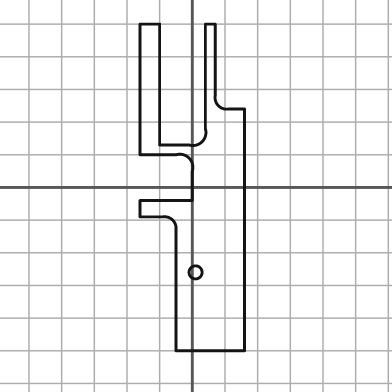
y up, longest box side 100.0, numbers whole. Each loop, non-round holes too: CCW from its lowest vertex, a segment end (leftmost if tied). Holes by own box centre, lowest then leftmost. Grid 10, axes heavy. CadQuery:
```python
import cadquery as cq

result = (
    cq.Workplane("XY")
    .moveTo(-5.0, -50.0)
    .lineTo(16.0, -50.0)
    .lineTo(16.0, 24.0)
    .lineTo(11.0, 24.0)
    .threePointArc((8.0, 25.0), (7.0, 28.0))
    .lineTo(7.0, 50.0)
    .lineTo(4.0, 50.0)
    .lineTo(4.0, 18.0)
    .threePointArc((3.0, 14.0), (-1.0, 13.0))
    .lineTo(-10.0, 13.0)
    .lineTo(-10.0, 50.0)
    .lineTo(-16.0, 50.0)
    .lineTo(-16.0, 10.0)
    .lineTo(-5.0, 10.0)
    .threePointArc((-1.0, 9.0), (0.0, 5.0))
    .lineTo(0.0, -4.0)
    .lineTo(-16.0, -4.0)
    .lineTo(-16.0, -9.0)
    .lineTo(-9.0, -9.0)
    .threePointArc((-6.0, -10.0), (-5.0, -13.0))
    .close()
    .moveTo(1.0, -26.0)
    .circle(2.0)
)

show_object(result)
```